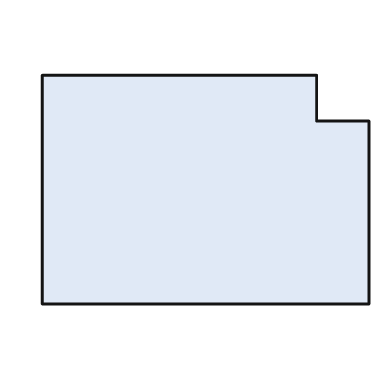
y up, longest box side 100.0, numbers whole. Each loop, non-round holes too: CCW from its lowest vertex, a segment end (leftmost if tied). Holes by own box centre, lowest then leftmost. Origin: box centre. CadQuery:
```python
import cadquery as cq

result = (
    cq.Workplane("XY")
    .moveTo(-50.0, -35.0)
    .lineTo(50.0, -35.0)
    .lineTo(50.0, 21.0)
    .lineTo(34.0, 21.0)
    .lineTo(34.0, 35.0)
    .lineTo(-50.0, 35.0)
    .close()
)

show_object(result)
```